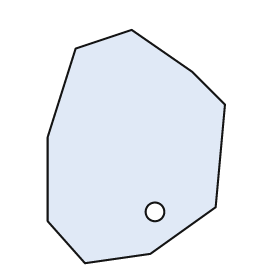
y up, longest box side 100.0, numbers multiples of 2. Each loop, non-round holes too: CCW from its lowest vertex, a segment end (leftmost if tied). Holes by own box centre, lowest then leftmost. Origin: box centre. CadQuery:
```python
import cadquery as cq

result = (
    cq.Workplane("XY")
    .moveTo(-22.0, -50.0)
    .lineTo(6.0, -46.0)
    .lineTo(34.0, -26.0)
    .lineTo(38.0, 18.0)
    .lineTo(24.0, 32.0)
    .lineTo(-2.0, 50.0)
    .lineTo(-26.0, 42.0)
    .lineTo(-38.0, 4.0)
    .lineTo(-38.0, -32.0)
    .close()
    .moveTo(8.0, -28.0)
    .circle(4.0)
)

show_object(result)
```